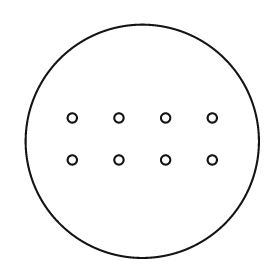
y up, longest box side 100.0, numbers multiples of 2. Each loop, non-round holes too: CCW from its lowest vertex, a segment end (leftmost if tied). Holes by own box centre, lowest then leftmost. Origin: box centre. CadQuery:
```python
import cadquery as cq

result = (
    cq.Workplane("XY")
    .moveTo(0.0, 0.0)
    .circle(50.0)
    .moveTo(-30.0, -8.0)
    .circle(2.0)
    .moveTo(-10.0, -8.0)
    .circle(2.0)
    .moveTo(10.0, -8.0)
    .circle(2.0)
    .moveTo(30.0, -8.0)
    .circle(2.0)
    .moveTo(-30.0, 10.0)
    .circle(2.0)
    .moveTo(-10.0, 10.0)
    .circle(2.0)
    .moveTo(10.0, 10.0)
    .circle(2.0)
    .moveTo(30.0, 10.0)
    .circle(2.0)
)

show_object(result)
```